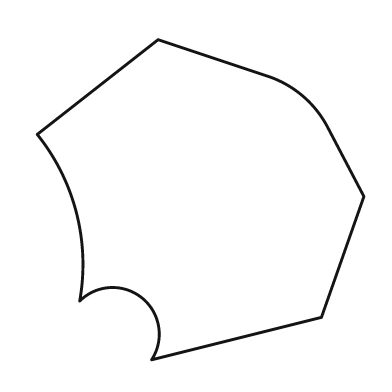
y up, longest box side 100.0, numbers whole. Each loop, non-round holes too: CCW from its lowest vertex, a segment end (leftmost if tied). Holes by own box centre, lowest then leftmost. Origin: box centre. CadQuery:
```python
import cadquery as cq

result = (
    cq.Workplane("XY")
    .moveTo(-15.0, -49.0)
    .lineTo(37.0, -36.0)
    .lineTo(50.0, 1.0)
    .lineTo(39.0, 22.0)
    .threePointArc((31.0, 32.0), (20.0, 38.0))
    .lineTo(-13.0, 49.0)
    .lineTo(-50.0, 20.0)
    .threePointArc((-38.0, -4.0), (-37.0, -31.0))
    .threePointArc((-18.0, -30.0), (-15.0, -49.0))
    .close()
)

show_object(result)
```